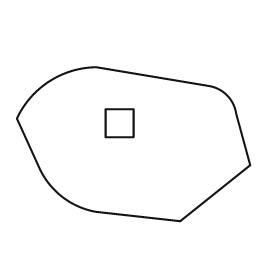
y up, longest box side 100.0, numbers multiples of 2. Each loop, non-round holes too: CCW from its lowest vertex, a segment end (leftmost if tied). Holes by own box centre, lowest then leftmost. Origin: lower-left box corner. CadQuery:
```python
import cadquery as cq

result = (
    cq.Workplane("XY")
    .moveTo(70.0, 0.0)
    .lineTo(100.0, 24.0)
    .lineTo(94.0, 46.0)
    .threePointArc((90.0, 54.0), (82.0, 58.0))
    .lineTo(34.0, 66.0)
    .threePointArc((14.0, 60.0), (0.0, 44.0))
    .lineTo(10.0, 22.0)
    .threePointArc((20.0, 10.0), (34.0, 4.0))
    .close()
    .moveTo(38.0, 36.0)
    .lineTo(50.0, 36.0)
    .lineTo(50.0, 48.0)
    .lineTo(38.0, 48.0)
    .close()
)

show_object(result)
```